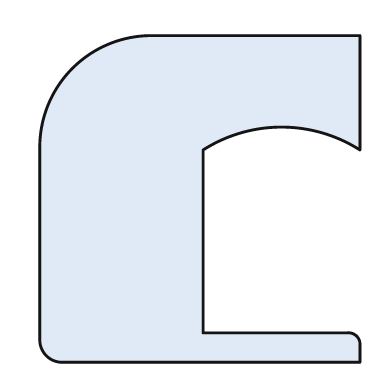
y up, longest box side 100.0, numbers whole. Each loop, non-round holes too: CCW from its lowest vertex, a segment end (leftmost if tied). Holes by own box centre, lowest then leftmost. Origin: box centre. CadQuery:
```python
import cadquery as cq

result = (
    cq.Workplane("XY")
    .moveTo(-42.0, -50.0)
    .lineTo(49.0, -50.0)
    .lineTo(49.0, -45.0)
    .threePointArc((48.0, -42.0), (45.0, -41.0))
    .lineTo(1.0, -41.0)
    .lineTo(1.0, 15.0)
    .threePointArc((25.0, 22.0), (49.0, 15.0))
    .lineTo(49.0, 50.0)
    .lineTo(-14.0, 50.0)
    .threePointArc((-39.0, 40.0), (-49.0, 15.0))
    .lineTo(-49.0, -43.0)
    .threePointArc((-47.0, -48.0), (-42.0, -50.0))
    .close()
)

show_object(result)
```